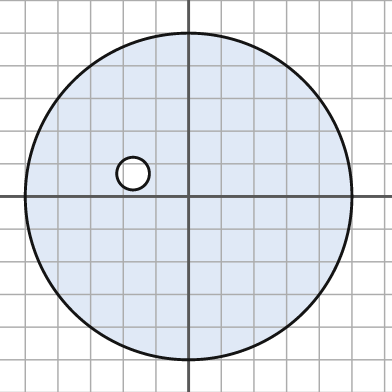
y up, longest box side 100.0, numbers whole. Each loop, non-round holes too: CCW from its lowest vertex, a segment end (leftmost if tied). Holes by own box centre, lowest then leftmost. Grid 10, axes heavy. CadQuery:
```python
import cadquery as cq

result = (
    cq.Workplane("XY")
    .moveTo(0.0, 0.0)
    .circle(50.0)
    .moveTo(-17.0, 7.0)
    .circle(5.0)
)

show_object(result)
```